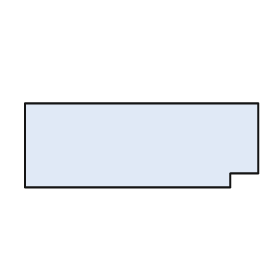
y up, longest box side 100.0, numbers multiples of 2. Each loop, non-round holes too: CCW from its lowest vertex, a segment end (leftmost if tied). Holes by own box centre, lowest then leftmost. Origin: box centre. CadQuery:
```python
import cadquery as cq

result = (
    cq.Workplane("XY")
    .moveTo(-50.0, -18.0)
    .lineTo(38.0, -18.0)
    .lineTo(38.0, -12.0)
    .lineTo(50.0, -12.0)
    .lineTo(50.0, 18.0)
    .lineTo(-50.0, 18.0)
    .close()
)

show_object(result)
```